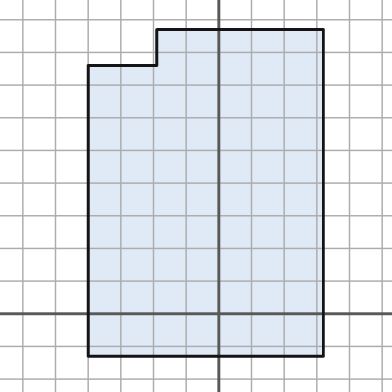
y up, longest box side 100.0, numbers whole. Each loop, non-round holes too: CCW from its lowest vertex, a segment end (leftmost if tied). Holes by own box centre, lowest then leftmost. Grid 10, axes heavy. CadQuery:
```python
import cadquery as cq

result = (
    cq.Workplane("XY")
    .moveTo(-40.0, -13.0)
    .lineTo(32.0, -13.0)
    .lineTo(32.0, 87.0)
    .lineTo(-19.0, 87.0)
    .lineTo(-19.0, 76.0)
    .lineTo(-40.0, 76.0)
    .close()
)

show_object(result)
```